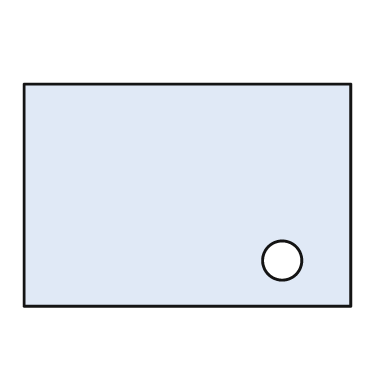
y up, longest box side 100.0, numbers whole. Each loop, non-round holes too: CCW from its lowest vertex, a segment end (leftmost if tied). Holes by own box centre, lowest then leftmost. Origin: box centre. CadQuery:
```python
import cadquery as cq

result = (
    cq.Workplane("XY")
    .moveTo(-50.0, -34.0)
    .lineTo(50.0, -34.0)
    .lineTo(50.0, 34.0)
    .lineTo(-50.0, 34.0)
    .close()
    .moveTo(29.0, -20.0)
    .circle(6.0)
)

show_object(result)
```